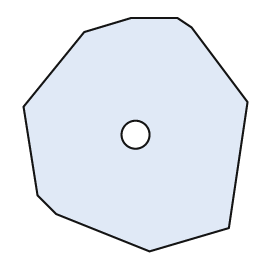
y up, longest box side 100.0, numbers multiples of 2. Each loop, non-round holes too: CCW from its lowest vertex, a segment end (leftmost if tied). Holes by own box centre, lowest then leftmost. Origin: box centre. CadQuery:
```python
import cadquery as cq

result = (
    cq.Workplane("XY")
    .moveTo(6.0, -50.0)
    .lineTo(40.0, -40.0)
    .lineTo(48.0, 14.0)
    .lineTo(24.0, 46.0)
    .lineTo(18.0, 50.0)
    .lineTo(-2.0, 50.0)
    .lineTo(-22.0, 44.0)
    .lineTo(-48.0, 12.0)
    .lineTo(-42.0, -26.0)
    .lineTo(-34.0, -34.0)
    .close()
    .moveTo(0.0, 0.0)
    .circle(6.0)
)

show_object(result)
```